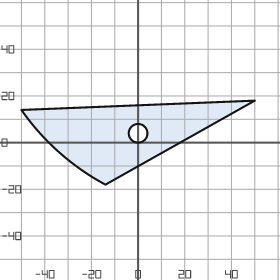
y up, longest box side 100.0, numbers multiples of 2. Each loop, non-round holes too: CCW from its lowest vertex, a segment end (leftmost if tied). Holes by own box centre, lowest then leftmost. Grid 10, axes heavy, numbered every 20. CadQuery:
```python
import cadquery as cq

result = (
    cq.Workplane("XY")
    .moveTo(-14.0, -18.0)
    .lineTo(50.0, 18.0)
    .lineTo(-50.0, 14.0)
    .threePointArc((-34.0, -4.0), (-14.0, -18.0))
    .close()
    .moveTo(0.0, 4.0)
    .circle(4.0)
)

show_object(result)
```